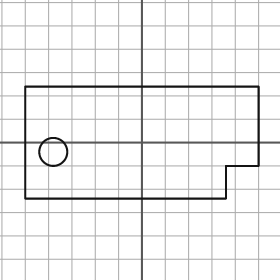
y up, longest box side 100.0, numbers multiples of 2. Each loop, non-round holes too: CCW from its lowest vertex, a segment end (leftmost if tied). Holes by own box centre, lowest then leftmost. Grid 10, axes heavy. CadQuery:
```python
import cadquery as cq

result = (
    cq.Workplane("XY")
    .moveTo(-50.0, -24.0)
    .lineTo(36.0, -24.0)
    .lineTo(36.0, -10.0)
    .lineTo(50.0, -10.0)
    .lineTo(50.0, 24.0)
    .lineTo(-50.0, 24.0)
    .close()
    .moveTo(-38.0, -4.0)
    .circle(6.0)
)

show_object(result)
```